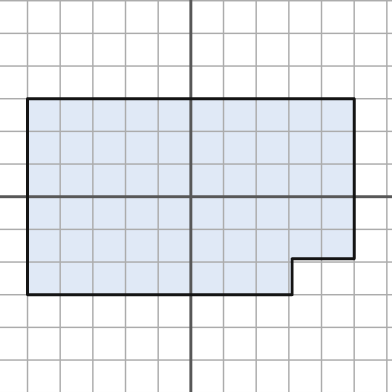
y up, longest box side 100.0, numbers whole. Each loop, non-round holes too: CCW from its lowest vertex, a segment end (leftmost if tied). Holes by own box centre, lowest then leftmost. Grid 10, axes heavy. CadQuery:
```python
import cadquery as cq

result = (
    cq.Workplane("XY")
    .moveTo(-50.0, -30.0)
    .lineTo(31.0, -30.0)
    .lineTo(31.0, -19.0)
    .lineTo(50.0, -19.0)
    .lineTo(50.0, 30.0)
    .lineTo(-50.0, 30.0)
    .close()
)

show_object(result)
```